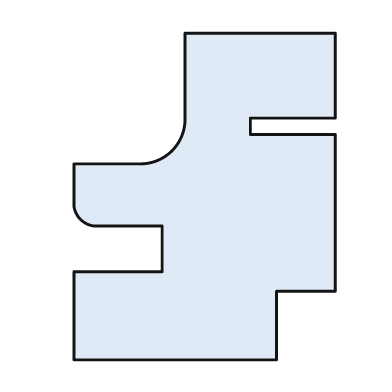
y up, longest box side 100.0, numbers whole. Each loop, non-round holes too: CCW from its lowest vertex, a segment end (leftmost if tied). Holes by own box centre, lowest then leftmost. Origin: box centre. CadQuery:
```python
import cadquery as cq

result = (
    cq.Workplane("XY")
    .moveTo(-40.0, -50.0)
    .lineTo(22.0, -50.0)
    .lineTo(22.0, -29.0)
    .lineTo(40.0, -29.0)
    .lineTo(40.0, 19.0)
    .lineTo(14.0, 19.0)
    .lineTo(14.0, 24.0)
    .lineTo(40.0, 24.0)
    .lineTo(40.0, 50.0)
    .lineTo(-6.0, 50.0)
    .lineTo(-6.0, 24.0)
    .threePointArc((-10.0, 14.0), (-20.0, 10.0))
    .lineTo(-40.0, 10.0)
    .lineTo(-40.0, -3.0)
    .threePointArc((-38.0, -7.0), (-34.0, -9.0))
    .lineTo(-13.0, -9.0)
    .lineTo(-13.0, -23.0)
    .lineTo(-40.0, -23.0)
    .close()
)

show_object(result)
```